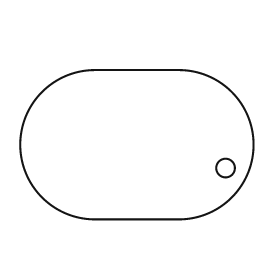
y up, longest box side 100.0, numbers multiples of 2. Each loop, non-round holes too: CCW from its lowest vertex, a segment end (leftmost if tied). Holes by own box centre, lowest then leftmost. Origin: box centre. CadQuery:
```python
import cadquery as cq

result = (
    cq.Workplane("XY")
    .moveTo(-18.0, -32.0)
    .lineTo(18.0, -32.0)
    .threePointArc((50.0, 0.0), (18.0, 32.0))
    .lineTo(-18.0, 32.0)
    .threePointArc((-50.0, 0.0), (-18.0, -32.0))
    .close()
    .moveTo(38.0, -10.0)
    .circle(4.0)
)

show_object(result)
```